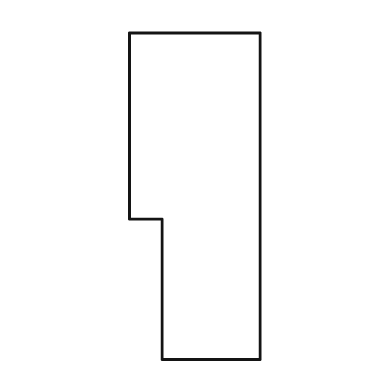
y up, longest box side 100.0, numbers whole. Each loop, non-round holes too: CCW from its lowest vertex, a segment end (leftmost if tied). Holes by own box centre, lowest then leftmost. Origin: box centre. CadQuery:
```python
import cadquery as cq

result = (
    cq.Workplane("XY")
    .moveTo(-10.0, -50.0)
    .lineTo(20.0, -50.0)
    .lineTo(20.0, 50.0)
    .lineTo(-20.0, 50.0)
    .lineTo(-20.0, -7.0)
    .lineTo(-10.0, -7.0)
    .close()
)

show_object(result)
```